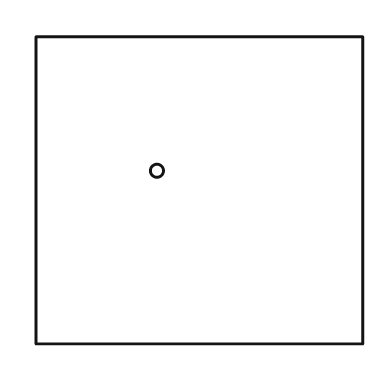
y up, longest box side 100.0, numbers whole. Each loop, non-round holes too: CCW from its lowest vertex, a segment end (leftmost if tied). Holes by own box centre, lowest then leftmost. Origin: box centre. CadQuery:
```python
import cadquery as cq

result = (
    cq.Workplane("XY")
    .moveTo(-50.0, -47.0)
    .lineTo(50.0, -47.0)
    .lineTo(50.0, 47.0)
    .lineTo(-50.0, 47.0)
    .close()
    .moveTo(-13.0, 6.0)
    .circle(2.0)
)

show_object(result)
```